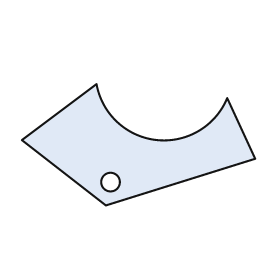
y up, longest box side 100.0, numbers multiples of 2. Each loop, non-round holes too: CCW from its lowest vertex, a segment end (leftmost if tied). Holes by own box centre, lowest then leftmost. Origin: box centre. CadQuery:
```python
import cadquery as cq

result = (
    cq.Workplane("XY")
    .moveTo(-14.0, -26.0)
    .lineTo(50.0, -6.0)
    .lineTo(38.0, 20.0)
    .threePointArc((8.0, 2.0), (-18.0, 26.0))
    .lineTo(-50.0, 2.0)
    .close()
    .moveTo(-12.0, -16.0)
    .circle(4.0)
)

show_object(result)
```